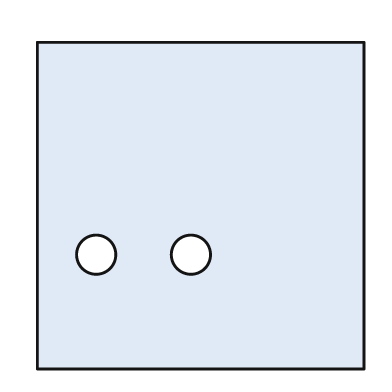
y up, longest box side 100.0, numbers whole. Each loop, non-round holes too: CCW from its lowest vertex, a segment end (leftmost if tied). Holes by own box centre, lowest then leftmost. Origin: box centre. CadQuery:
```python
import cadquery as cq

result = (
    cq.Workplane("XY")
    .moveTo(-50.0, -50.0)
    .lineTo(50.0, -50.0)
    .lineTo(50.0, 50.0)
    .lineTo(-50.0, 50.0)
    .close()
    .moveTo(-32.0, -15.0)
    .circle(6.0)
    .moveTo(-3.0, -15.0)
    .circle(6.0)
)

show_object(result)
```